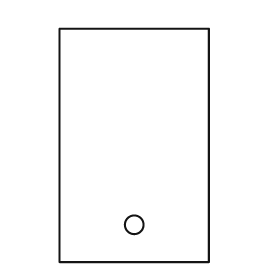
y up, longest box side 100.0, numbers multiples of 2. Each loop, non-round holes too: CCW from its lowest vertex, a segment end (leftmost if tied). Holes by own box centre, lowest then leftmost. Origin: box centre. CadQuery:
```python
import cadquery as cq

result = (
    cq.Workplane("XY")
    .moveTo(-32.0, -50.0)
    .lineTo(32.0, -50.0)
    .lineTo(32.0, 50.0)
    .lineTo(-32.0, 50.0)
    .close()
    .moveTo(0.0, -34.0)
    .circle(4.0)
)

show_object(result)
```